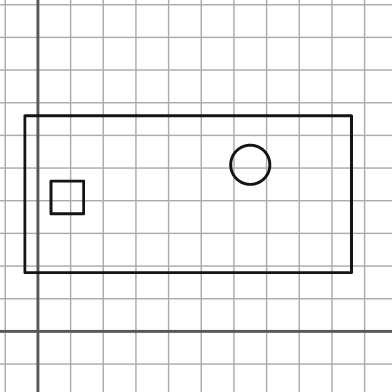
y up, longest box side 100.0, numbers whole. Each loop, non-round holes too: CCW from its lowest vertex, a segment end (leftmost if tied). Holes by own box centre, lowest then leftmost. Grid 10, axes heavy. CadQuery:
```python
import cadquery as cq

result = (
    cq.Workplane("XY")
    .moveTo(-4.0, 18.0)
    .lineTo(96.0, 18.0)
    .lineTo(96.0, 66.0)
    .lineTo(-4.0, 66.0)
    .close()
    .moveTo(4.0, 36.0)
    .lineTo(14.0, 36.0)
    .lineTo(14.0, 46.0)
    .lineTo(4.0, 46.0)
    .close()
    .moveTo(65.0, 51.0)
    .circle(6.0)
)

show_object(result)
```